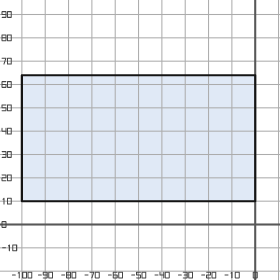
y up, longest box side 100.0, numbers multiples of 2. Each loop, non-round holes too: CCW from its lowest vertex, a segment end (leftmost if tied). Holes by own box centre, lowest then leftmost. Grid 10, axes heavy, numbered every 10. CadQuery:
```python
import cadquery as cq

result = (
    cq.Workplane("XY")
    .moveTo(-100.0, 10.0)
    .lineTo(0.0, 10.0)
    .lineTo(0.0, 64.0)
    .lineTo(-100.0, 64.0)
    .close()
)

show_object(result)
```